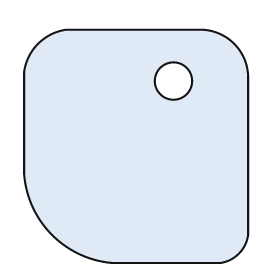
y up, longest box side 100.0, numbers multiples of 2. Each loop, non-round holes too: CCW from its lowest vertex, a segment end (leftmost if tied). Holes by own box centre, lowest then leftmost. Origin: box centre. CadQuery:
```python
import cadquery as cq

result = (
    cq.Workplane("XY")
    .moveTo(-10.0, -50.0)
    .lineTo(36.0, -50.0)
    .threePointArc((44.0, -46.0), (48.0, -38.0))
    .lineTo(48.0, 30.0)
    .threePointArc((42.0, 44.0), (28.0, 50.0))
    .lineTo(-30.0, 50.0)
    .threePointArc((-42.0, 44.0), (-48.0, 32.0))
    .lineTo(-48.0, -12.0)
    .threePointArc((-36.0, -38.0), (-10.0, -50.0))
    .close()
    .moveTo(16.0, 28.0)
    .circle(8.0)
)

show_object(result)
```